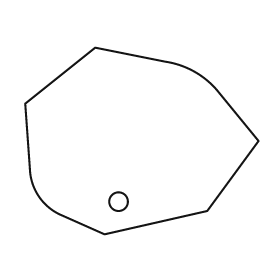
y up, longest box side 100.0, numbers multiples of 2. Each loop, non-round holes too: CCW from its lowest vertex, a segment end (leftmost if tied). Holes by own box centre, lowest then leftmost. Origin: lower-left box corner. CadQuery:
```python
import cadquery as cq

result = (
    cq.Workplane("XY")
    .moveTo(34.0, 0.0)
    .lineTo(78.0, 10.0)
    .lineTo(100.0, 40.0)
    .lineTo(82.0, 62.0)
    .threePointArc((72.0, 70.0), (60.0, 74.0))
    .lineTo(30.0, 80.0)
    .lineTo(0.0, 56.0)
    .lineTo(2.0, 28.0)
    .threePointArc((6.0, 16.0), (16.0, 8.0))
    .close()
    .moveTo(40.0, 14.0)
    .circle(4.0)
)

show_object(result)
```